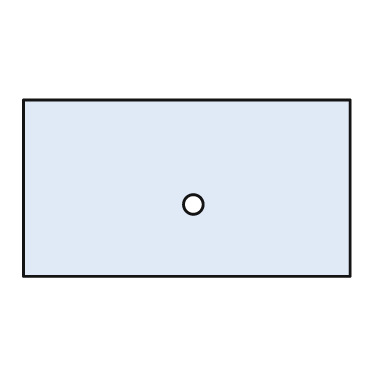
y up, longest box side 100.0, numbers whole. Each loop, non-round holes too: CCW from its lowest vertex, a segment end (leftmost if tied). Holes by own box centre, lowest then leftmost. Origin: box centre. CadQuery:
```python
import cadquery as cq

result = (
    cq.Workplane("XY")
    .moveTo(-50.0, -27.0)
    .lineTo(50.0, -27.0)
    .lineTo(50.0, 27.0)
    .lineTo(-50.0, 27.0)
    .close()
    .moveTo(2.0, -5.0)
    .circle(3.0)
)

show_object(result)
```